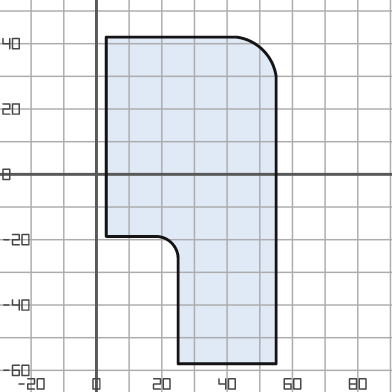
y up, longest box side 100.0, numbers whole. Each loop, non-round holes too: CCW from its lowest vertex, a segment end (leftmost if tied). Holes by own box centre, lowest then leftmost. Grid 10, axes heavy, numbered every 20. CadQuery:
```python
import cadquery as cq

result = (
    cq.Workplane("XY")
    .moveTo(25.0, -58.0)
    .lineTo(55.0, -58.0)
    .lineTo(55.0, 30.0)
    .threePointArc((51.0, 38.0), (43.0, 42.0))
    .lineTo(3.0, 42.0)
    .lineTo(3.0, -19.0)
    .lineTo(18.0, -19.0)
    .threePointArc((23.0, -21.0), (25.0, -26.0))
    .close()
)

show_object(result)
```